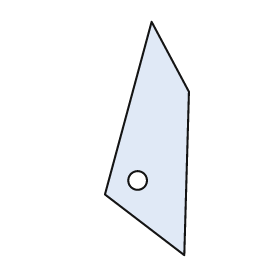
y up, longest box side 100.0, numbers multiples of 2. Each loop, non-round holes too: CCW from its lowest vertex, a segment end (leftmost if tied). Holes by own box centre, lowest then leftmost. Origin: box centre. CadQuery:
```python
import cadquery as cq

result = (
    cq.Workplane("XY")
    .moveTo(16.0, -50.0)
    .lineTo(18.0, 20.0)
    .lineTo(2.0, 50.0)
    .lineTo(-18.0, -24.0)
    .close()
    .moveTo(-4.0, -18.0)
    .circle(4.0)
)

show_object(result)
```